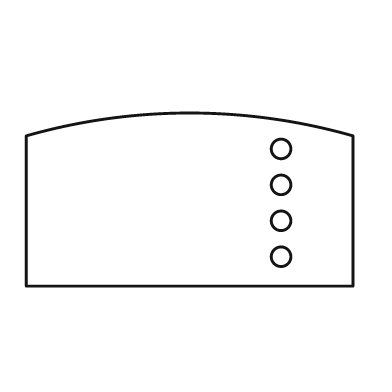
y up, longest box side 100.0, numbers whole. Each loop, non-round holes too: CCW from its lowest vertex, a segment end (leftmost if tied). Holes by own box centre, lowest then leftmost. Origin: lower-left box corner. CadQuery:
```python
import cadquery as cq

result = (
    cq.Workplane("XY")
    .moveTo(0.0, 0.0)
    .lineTo(100.0, 0.0)
    .lineTo(100.0, 46.0)
    .threePointArc((50.0, 53.0), (0.0, 46.0))
    .close()
    .moveTo(78.0, 9.0)
    .circle(3.0)
    .moveTo(78.0, 20.0)
    .circle(3.0)
    .moveTo(78.0, 31.0)
    .circle(3.0)
    .moveTo(78.0, 42.0)
    .circle(3.0)
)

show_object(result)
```